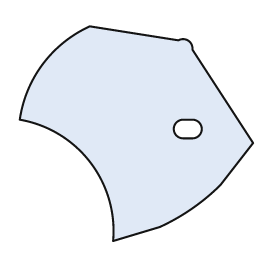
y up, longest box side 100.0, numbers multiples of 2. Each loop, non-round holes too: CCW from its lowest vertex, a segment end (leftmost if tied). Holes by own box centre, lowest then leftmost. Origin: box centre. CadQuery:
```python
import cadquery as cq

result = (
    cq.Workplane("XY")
    .moveTo(-10.0, -46.0)
    .lineTo(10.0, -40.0)
    .threePointArc((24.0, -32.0), (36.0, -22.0))
    .lineTo(50.0, -4.0)
    .lineTo(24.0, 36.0)
    .threePointArc((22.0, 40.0), (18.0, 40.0))
    .lineTo(-20.0, 46.0)
    .threePointArc((-40.0, 30.0), (-50.0, 6.0))
    .threePointArc((-20.0, -12.0), (-10.0, -46.0))
    .close()
    .moveTo(20.0, -2.0)
    .lineTo(24.0, -2.0)
    .threePointArc((28.0, 2.0), (24.0, 6.0))
    .lineTo(20.0, 6.0)
    .threePointArc((16.0, 2.0), (20.0, -2.0))
    .close()
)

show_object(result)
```